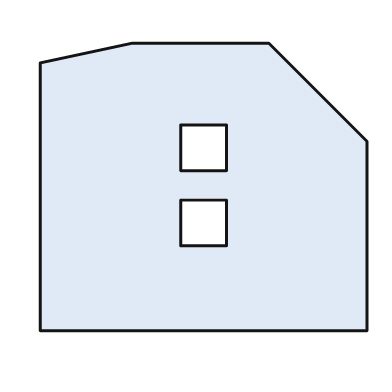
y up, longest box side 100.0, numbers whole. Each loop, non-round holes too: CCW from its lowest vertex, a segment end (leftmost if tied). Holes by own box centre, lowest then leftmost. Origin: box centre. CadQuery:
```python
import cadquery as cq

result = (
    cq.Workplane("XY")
    .moveTo(-50.0, -44.0)
    .lineTo(50.0, -44.0)
    .lineTo(50.0, 14.0)
    .lineTo(20.0, 44.0)
    .lineTo(-22.0, 44.0)
    .lineTo(-50.0, 38.0)
    .close()
    .moveTo(-7.0, -18.0)
    .lineTo(7.0, -18.0)
    .lineTo(7.0, -4.0)
    .lineTo(-7.0, -4.0)
    .close()
    .moveTo(-7.0, 5.0)
    .lineTo(7.0, 5.0)
    .lineTo(7.0, 19.0)
    .lineTo(-7.0, 19.0)
    .close()
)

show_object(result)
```